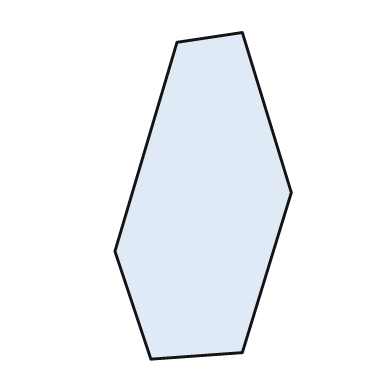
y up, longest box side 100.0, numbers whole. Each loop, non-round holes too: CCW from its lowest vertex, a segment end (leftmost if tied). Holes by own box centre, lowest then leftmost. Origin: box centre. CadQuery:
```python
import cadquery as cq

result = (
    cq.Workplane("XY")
    .moveTo(-16.0, -50.0)
    .lineTo(12.0, -48.0)
    .lineTo(27.0, 1.0)
    .lineTo(12.0, 50.0)
    .lineTo(-8.0, 47.0)
    .lineTo(-27.0, -17.0)
    .close()
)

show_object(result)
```